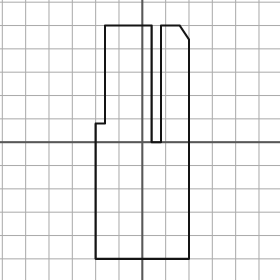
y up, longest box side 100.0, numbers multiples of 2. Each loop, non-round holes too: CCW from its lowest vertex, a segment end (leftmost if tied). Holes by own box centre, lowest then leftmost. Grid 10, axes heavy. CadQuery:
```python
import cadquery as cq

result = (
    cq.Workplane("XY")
    .moveTo(-20.0, -50.0)
    .lineTo(20.0, -50.0)
    .lineTo(20.0, 44.0)
    .lineTo(16.0, 50.0)
    .lineTo(8.0, 50.0)
    .lineTo(8.0, 0.0)
    .lineTo(4.0, 0.0)
    .lineTo(4.0, 50.0)
    .lineTo(-16.0, 50.0)
    .lineTo(-16.0, 8.0)
    .lineTo(-20.0, 8.0)
    .close()
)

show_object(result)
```